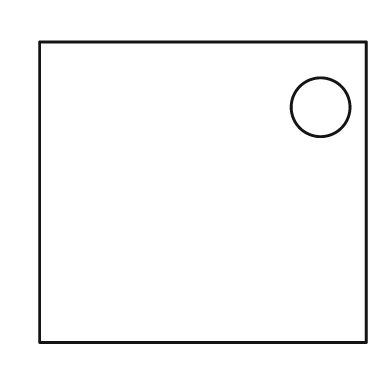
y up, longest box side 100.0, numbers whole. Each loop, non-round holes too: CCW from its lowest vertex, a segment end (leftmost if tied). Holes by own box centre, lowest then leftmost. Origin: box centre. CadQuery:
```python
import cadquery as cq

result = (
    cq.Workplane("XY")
    .moveTo(-50.0, -46.0)
    .lineTo(50.0, -46.0)
    .lineTo(50.0, 46.0)
    .lineTo(-50.0, 46.0)
    .close()
    .moveTo(36.0, 26.0)
    .circle(9.0)
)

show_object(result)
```